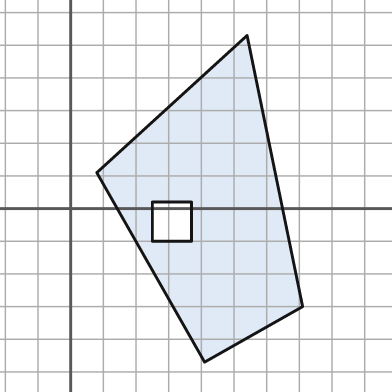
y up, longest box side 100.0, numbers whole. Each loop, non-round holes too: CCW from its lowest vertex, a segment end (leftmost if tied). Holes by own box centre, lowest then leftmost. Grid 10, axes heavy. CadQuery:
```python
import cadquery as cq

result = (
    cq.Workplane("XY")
    .moveTo(41.0, -47.0)
    .lineTo(71.0, -30.0)
    .lineTo(54.0, 53.0)
    .lineTo(8.0, 11.0)
    .close()
    .moveTo(25.0, -10.0)
    .lineTo(37.0, -10.0)
    .lineTo(37.0, 2.0)
    .lineTo(25.0, 2.0)
    .close()
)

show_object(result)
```